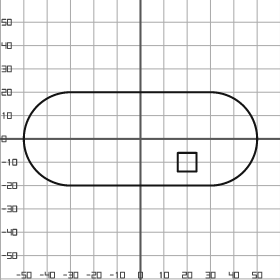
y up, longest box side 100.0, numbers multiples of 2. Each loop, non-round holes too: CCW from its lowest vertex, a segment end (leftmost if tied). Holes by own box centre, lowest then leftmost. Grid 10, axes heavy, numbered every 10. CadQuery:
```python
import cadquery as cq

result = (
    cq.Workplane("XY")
    .moveTo(-30.0, -20.0)
    .lineTo(30.0, -20.0)
    .threePointArc((50.0, 0.0), (30.0, 20.0))
    .lineTo(-30.0, 20.0)
    .threePointArc((-50.0, 0.0), (-30.0, -20.0))
    .close()
    .moveTo(16.0, -14.0)
    .lineTo(24.0, -14.0)
    .lineTo(24.0, -6.0)
    .lineTo(16.0, -6.0)
    .close()
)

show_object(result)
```